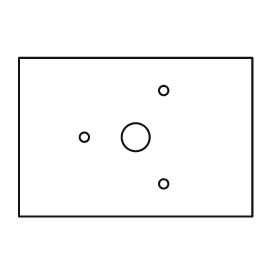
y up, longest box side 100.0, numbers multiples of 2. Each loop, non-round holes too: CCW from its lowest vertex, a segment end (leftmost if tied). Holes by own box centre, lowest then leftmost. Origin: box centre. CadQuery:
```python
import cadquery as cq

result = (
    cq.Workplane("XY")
    .moveTo(-50.0, -34.0)
    .lineTo(50.0, -34.0)
    .lineTo(50.0, 34.0)
    .lineTo(-50.0, 34.0)
    .close()
    .moveTo(12.0, -20.0)
    .circle(2.0)
    .moveTo(-22.0, 0.0)
    .circle(2.0)
    .moveTo(0.0, 0.0)
    .circle(6.0)
    .moveTo(12.0, 20.0)
    .circle(2.0)
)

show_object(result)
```